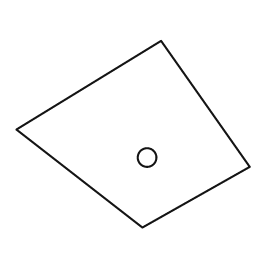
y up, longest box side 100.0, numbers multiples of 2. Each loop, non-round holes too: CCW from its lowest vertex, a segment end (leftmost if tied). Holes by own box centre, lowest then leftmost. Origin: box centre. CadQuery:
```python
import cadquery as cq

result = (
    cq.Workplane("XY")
    .moveTo(4.0, -40.0)
    .lineTo(50.0, -14.0)
    .lineTo(12.0, 40.0)
    .lineTo(-50.0, 2.0)
    .close()
    .moveTo(6.0, -10.0)
    .circle(4.0)
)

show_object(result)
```